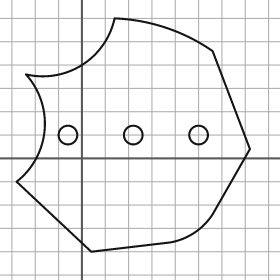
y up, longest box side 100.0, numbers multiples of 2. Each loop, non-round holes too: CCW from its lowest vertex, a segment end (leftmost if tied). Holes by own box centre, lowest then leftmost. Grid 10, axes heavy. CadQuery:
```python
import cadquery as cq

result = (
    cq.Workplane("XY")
    .moveTo(4.0, -40.0)
    .lineTo(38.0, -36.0)
    .threePointArc((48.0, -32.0), (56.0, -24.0))
    .lineTo(72.0, 4.0)
    .lineTo(56.0, 46.0)
    .threePointArc((36.0, 56.0), (14.0, 60.0))
    .threePointArc((0.0, 40.0), (-24.0, 36.0))
    .threePointArc((-16.0, 12.0), (-28.0, -10.0))
    .close()
    .moveTo(-6.0, 10.0)
    .circle(4.0)
    .moveTo(22.0, 10.0)
    .circle(4.0)
    .moveTo(50.0, 10.0)
    .circle(4.0)
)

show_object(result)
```